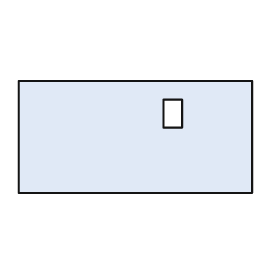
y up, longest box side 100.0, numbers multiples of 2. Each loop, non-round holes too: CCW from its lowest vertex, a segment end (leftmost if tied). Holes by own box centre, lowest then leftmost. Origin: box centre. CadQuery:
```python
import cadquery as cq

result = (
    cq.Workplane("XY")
    .moveTo(-50.0, -24.0)
    .lineTo(50.0, -24.0)
    .lineTo(50.0, 24.0)
    .lineTo(-50.0, 24.0)
    .close()
    .moveTo(12.0, 4.0)
    .lineTo(20.0, 4.0)
    .lineTo(20.0, 16.0)
    .lineTo(12.0, 16.0)
    .close()
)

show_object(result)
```